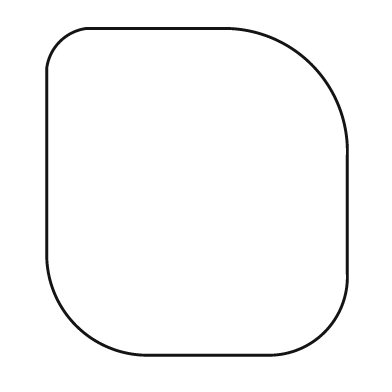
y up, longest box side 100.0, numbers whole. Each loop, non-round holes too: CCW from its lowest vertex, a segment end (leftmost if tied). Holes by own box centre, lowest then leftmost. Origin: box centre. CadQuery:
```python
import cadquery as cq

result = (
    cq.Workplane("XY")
    .moveTo(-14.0, -50.0)
    .lineTo(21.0, -50.0)
    .threePointArc((39.0, -43.0), (46.0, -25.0))
    .lineTo(46.0, 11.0)
    .threePointArc((35.0, 39.0), (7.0, 50.0))
    .lineTo(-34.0, 50.0)
    .threePointArc((-42.0, 46.0), (-46.0, 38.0))
    .lineTo(-46.0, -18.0)
    .threePointArc((-37.0, -41.0), (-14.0, -50.0))
    .close()
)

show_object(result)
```